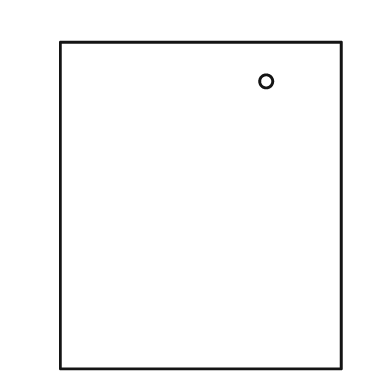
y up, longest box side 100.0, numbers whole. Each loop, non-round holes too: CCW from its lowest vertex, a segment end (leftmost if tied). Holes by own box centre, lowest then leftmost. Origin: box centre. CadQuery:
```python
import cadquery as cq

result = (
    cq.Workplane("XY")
    .moveTo(-43.0, -50.0)
    .lineTo(43.0, -50.0)
    .lineTo(43.0, 50.0)
    .lineTo(-43.0, 50.0)
    .close()
    .moveTo(20.0, 38.0)
    .circle(2.0)
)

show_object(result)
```